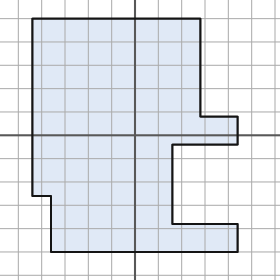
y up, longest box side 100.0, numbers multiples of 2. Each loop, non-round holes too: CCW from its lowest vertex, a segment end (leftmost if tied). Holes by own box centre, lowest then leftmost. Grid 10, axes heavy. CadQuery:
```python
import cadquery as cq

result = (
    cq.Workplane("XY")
    .moveTo(-36.0, -50.0)
    .lineTo(44.0, -50.0)
    .lineTo(44.0, -38.0)
    .lineTo(16.0, -38.0)
    .lineTo(16.0, -4.0)
    .lineTo(44.0, -4.0)
    .lineTo(44.0, 8.0)
    .lineTo(28.0, 8.0)
    .lineTo(28.0, 50.0)
    .lineTo(-44.0, 50.0)
    .lineTo(-44.0, -26.0)
    .lineTo(-36.0, -26.0)
    .close()
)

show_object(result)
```